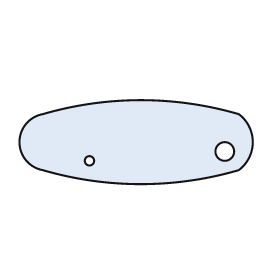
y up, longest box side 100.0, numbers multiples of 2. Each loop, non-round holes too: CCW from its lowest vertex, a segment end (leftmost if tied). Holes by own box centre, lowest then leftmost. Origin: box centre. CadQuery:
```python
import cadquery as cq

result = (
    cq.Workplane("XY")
    .moveTo(-40.0, -12.0)
    .threePointArc((2.0, -18.0), (44.0, -12.0))
    .threePointArc((50.0, 0.0), (44.0, 12.0))
    .threePointArc((2.0, 18.0), (-40.0, 12.0))
    .threePointArc((-50.0, 0.0), (-40.0, -12.0))
    .close()
    .moveTo(-20.0, -8.0)
    .circle(2.0)
    .moveTo(38.0, -4.0)
    .circle(4.0)
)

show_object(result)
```